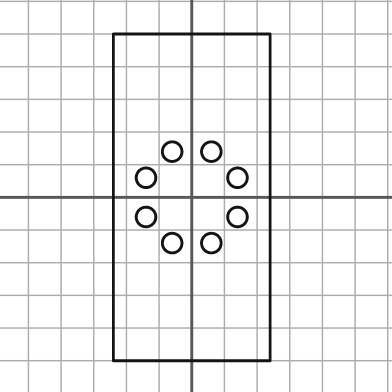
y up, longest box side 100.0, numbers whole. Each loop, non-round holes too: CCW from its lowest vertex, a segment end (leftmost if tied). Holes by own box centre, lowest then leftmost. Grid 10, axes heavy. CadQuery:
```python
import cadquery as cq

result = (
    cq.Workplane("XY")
    .moveTo(-24.0, -50.0)
    .lineTo(24.0, -50.0)
    .lineTo(24.0, 50.0)
    .lineTo(-24.0, 50.0)
    .close()
    .moveTo(-6.0, -14.0)
    .circle(3.0)
    .moveTo(6.0, -14.0)
    .circle(3.0)
    .moveTo(-14.0, -6.0)
    .circle(3.0)
    .moveTo(14.0, -6.0)
    .circle(3.0)
    .moveTo(-14.0, 6.0)
    .circle(3.0)
    .moveTo(14.0, 6.0)
    .circle(3.0)
    .moveTo(-6.0, 14.0)
    .circle(3.0)
    .moveTo(6.0, 14.0)
    .circle(3.0)
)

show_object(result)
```